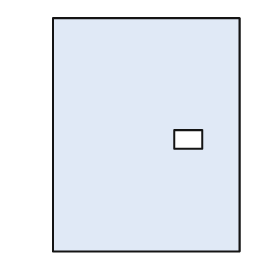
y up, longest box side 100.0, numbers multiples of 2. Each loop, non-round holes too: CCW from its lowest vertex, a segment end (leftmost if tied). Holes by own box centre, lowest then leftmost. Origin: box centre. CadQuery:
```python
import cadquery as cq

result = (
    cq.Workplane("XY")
    .moveTo(-40.0, -50.0)
    .lineTo(40.0, -50.0)
    .lineTo(40.0, 50.0)
    .lineTo(-40.0, 50.0)
    .close()
    .moveTo(12.0, -6.0)
    .lineTo(24.0, -6.0)
    .lineTo(24.0, 2.0)
    .lineTo(12.0, 2.0)
    .close()
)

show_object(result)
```